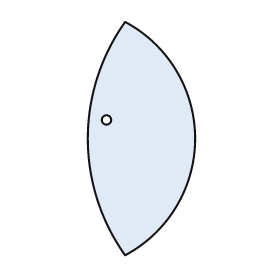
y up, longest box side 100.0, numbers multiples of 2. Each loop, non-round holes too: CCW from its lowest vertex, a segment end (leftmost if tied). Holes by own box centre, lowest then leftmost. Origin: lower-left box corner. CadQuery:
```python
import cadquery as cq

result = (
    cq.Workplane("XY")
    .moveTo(16.0, 0.0)
    .threePointArc((46.0, 50.0), (16.0, 100.0))
    .threePointArc((0.0, 50.0), (16.0, 0.0))
    .close()
    .moveTo(8.0, 58.0)
    .circle(2.0)
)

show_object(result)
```